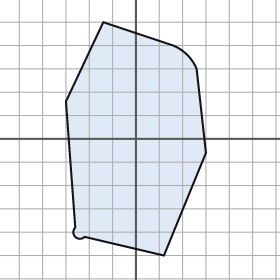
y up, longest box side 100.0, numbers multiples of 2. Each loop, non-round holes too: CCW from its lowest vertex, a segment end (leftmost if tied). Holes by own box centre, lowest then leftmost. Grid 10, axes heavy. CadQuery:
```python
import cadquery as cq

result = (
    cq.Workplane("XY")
    .moveTo(12.0, -50.0)
    .lineTo(30.0, -6.0)
    .lineTo(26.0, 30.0)
    .threePointArc((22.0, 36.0), (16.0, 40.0))
    .lineTo(-14.0, 50.0)
    .lineTo(-30.0, 16.0)
    .lineTo(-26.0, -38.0)
    .threePointArc((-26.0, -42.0), (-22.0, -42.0))
    .close()
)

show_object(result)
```